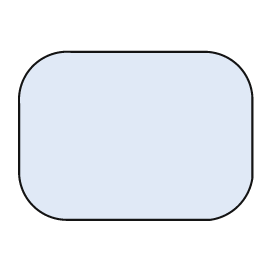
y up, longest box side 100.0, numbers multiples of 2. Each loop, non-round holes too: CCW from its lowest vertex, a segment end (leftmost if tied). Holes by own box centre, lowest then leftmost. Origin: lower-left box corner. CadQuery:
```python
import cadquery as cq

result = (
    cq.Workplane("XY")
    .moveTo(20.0, 0.0)
    .lineTo(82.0, 0.0)
    .threePointArc((94.0, 6.0), (100.0, 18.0))
    .lineTo(100.0, 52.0)
    .threePointArc((94.0, 66.0), (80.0, 72.0))
    .lineTo(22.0, 72.0)
    .threePointArc((6.0, 66.0), (0.0, 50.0))
    .lineTo(0.0, 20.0)
    .threePointArc((6.0, 6.0), (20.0, 0.0))
    .close()
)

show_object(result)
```